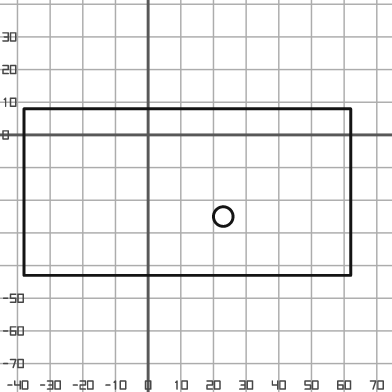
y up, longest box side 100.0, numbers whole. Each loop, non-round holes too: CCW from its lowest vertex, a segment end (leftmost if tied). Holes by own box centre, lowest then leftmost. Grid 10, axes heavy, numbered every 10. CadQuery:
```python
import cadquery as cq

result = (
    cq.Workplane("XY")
    .moveTo(-38.0, -43.0)
    .lineTo(62.0, -43.0)
    .lineTo(62.0, 8.0)
    .lineTo(-38.0, 8.0)
    .close()
    .moveTo(23.0, -25.0)
    .circle(3.0)
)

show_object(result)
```